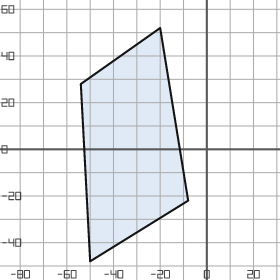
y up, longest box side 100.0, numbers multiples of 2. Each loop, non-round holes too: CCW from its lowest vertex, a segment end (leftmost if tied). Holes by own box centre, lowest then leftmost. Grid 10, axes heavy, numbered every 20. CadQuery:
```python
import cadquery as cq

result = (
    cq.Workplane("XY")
    .moveTo(-50.0, -48.0)
    .lineTo(-8.0, -22.0)
    .lineTo(-20.0, 52.0)
    .lineTo(-54.0, 28.0)
    .close()
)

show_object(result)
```